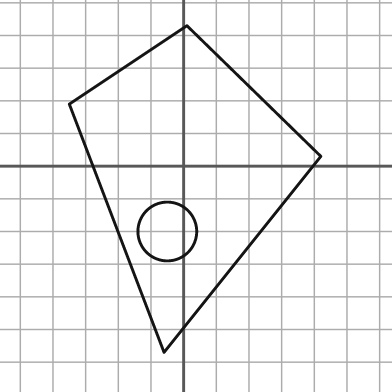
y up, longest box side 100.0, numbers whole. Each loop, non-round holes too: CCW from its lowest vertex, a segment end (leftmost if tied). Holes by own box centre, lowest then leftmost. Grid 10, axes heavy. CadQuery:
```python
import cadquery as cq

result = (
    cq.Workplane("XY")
    .moveTo(-6.0, -57.0)
    .lineTo(42.0, 3.0)
    .lineTo(1.0, 43.0)
    .lineTo(-35.0, 19.0)
    .close()
    .moveTo(-5.0, -20.0)
    .circle(9.0)
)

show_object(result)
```